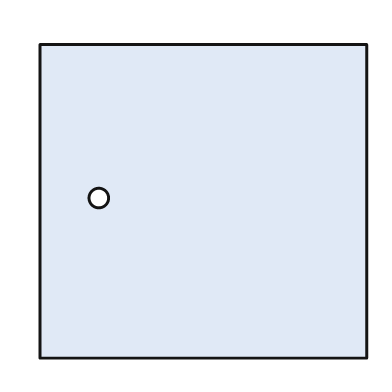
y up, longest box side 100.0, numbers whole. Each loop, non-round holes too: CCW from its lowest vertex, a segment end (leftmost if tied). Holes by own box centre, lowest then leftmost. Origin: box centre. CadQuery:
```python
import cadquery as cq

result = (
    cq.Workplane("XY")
    .moveTo(-50.0, -48.0)
    .lineTo(50.0, -48.0)
    .lineTo(50.0, 48.0)
    .lineTo(-50.0, 48.0)
    .close()
    .moveTo(-32.0, 1.0)
    .circle(3.0)
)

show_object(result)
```